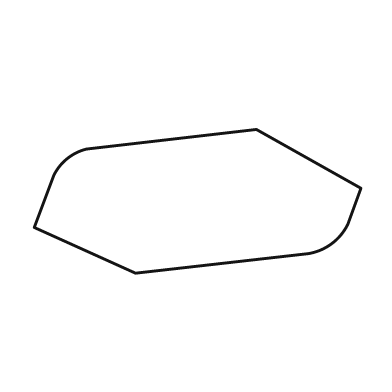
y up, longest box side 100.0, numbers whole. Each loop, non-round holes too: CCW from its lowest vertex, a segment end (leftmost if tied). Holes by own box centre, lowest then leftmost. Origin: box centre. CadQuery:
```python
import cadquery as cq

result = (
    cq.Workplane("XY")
    .moveTo(-19.0, -22.0)
    .lineTo(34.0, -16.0)
    .threePointArc((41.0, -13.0), (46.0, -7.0))
    .lineTo(50.0, 4.0)
    .lineTo(18.0, 22.0)
    .lineTo(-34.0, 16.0)
    .threePointArc((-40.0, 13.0), (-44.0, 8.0))
    .lineTo(-50.0, -8.0)
    .close()
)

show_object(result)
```